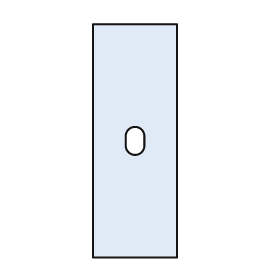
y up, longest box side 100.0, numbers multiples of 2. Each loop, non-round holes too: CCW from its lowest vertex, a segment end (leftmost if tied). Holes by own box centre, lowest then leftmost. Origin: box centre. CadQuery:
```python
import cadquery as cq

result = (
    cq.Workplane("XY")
    .moveTo(-18.0, -50.0)
    .lineTo(18.0, -50.0)
    .lineTo(18.0, 50.0)
    .lineTo(-18.0, 50.0)
    .close()
    .moveTo(-4.0, -2.0)
    .threePointArc((0.0, -6.0), (4.0, -2.0))
    .lineTo(4.0, 2.0)
    .threePointArc((0.0, 6.0), (-4.0, 2.0))
    .close()
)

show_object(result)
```